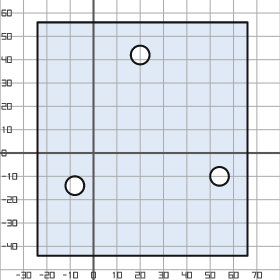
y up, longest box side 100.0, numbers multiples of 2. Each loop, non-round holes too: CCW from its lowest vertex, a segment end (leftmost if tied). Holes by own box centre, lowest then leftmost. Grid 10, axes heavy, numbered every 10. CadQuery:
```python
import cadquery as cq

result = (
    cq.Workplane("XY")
    .moveTo(-24.0, -44.0)
    .lineTo(66.0, -44.0)
    .lineTo(66.0, 56.0)
    .lineTo(-24.0, 56.0)
    .close()
    .moveTo(-8.0, -14.0)
    .circle(4.0)
    .moveTo(54.0, -10.0)
    .circle(4.0)
    .moveTo(20.0, 42.0)
    .circle(4.0)
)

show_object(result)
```